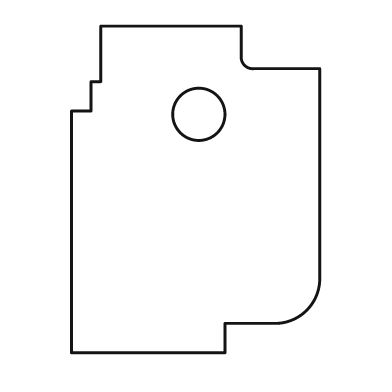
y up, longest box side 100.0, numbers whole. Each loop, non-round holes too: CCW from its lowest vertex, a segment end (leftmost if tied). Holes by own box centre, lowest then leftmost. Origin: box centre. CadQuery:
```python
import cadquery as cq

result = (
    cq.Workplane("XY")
    .moveTo(-38.0, -50.0)
    .lineTo(9.0, -50.0)
    .lineTo(9.0, -41.0)
    .lineTo(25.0, -41.0)
    .threePointArc((34.0, -37.0), (38.0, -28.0))
    .lineTo(38.0, 37.0)
    .lineTo(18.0, 37.0)
    .threePointArc((15.0, 38.0), (14.0, 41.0))
    .lineTo(14.0, 50.0)
    .lineTo(-29.0, 50.0)
    .lineTo(-29.0, 33.0)
    .lineTo(-32.0, 33.0)
    .lineTo(-32.0, 24.0)
    .lineTo(-38.0, 24.0)
    .close()
    .moveTo(1.0, 23.0)
    .circle(8.0)
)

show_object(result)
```